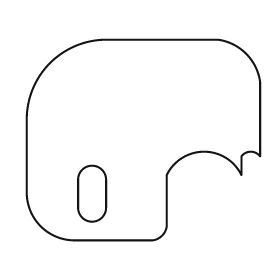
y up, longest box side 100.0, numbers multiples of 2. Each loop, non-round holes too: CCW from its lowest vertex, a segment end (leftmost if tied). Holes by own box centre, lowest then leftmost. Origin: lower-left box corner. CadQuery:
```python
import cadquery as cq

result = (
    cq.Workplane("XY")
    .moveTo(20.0, 0.0)
    .lineTo(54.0, 0.0)
    .threePointArc((58.0, 2.0), (60.0, 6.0))
    .lineTo(60.0, 28.0)
    .threePointArc((76.0, 38.0), (92.0, 28.0))
    .lineTo(92.0, 36.0)
    .threePointArc((96.0, 38.0), (100.0, 36.0))
    .lineTo(100.0, 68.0)
    .threePointArc((94.0, 80.0), (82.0, 86.0))
    .lineTo(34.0, 86.0)
    .threePointArc((10.0, 76.0), (0.0, 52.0))
    .lineTo(0.0, 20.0)
    .threePointArc((6.0, 6.0), (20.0, 0.0))
    .close()
    .moveTo(22.0, 14.0)
    .threePointArc((28.0, 8.0), (34.0, 14.0))
    .lineTo(34.0, 26.0)
    .threePointArc((28.0, 32.0), (22.0, 26.0))
    .close()
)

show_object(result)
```